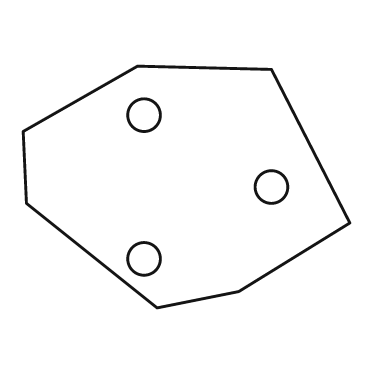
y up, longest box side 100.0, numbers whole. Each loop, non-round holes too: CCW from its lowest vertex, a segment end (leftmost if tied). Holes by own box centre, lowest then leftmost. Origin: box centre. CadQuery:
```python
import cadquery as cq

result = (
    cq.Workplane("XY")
    .moveTo(-9.0, -37.0)
    .lineTo(16.0, -32.0)
    .lineTo(50.0, -11.0)
    .lineTo(26.0, 36.0)
    .lineTo(-15.0, 37.0)
    .lineTo(-50.0, 17.0)
    .lineTo(-49.0, -5.0)
    .close()
    .moveTo(-13.0, -22.0)
    .circle(5.0)
    .moveTo(26.0, 0.0)
    .circle(5.0)
    .moveTo(-13.0, 22.0)
    .circle(5.0)
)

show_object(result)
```